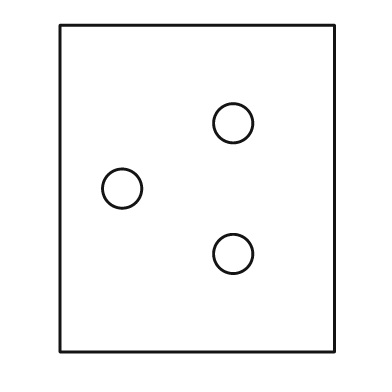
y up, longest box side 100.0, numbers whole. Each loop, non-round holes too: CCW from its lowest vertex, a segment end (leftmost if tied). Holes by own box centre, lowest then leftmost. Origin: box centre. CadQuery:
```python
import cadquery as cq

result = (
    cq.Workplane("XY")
    .moveTo(-42.0, -50.0)
    .lineTo(42.0, -50.0)
    .lineTo(42.0, 50.0)
    .lineTo(-42.0, 50.0)
    .close()
    .moveTo(11.0, -20.0)
    .circle(6.0)
    .moveTo(-23.0, 0.0)
    .circle(6.0)
    .moveTo(11.0, 20.0)
    .circle(6.0)
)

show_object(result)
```